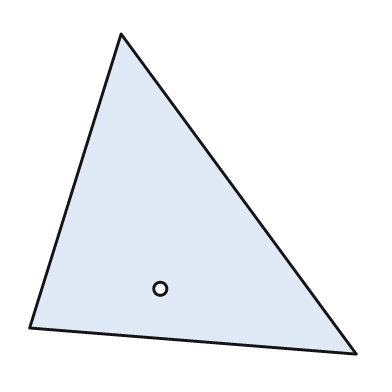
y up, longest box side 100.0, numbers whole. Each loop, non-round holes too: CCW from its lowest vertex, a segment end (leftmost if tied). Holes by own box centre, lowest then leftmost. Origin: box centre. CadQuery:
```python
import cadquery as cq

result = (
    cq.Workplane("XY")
    .moveTo(50.0, -49.0)
    .lineTo(-22.0, 49.0)
    .lineTo(-50.0, -41.0)
    .close()
    .moveTo(-10.0, -29.0)
    .circle(2.0)
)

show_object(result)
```